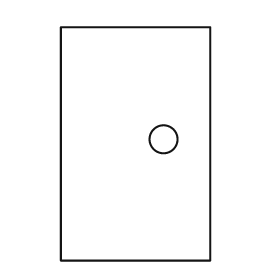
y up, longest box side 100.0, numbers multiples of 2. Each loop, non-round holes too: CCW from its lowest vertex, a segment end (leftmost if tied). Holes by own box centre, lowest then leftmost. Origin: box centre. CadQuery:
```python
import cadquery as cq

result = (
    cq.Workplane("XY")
    .moveTo(-32.0, -50.0)
    .lineTo(32.0, -50.0)
    .lineTo(32.0, 50.0)
    .lineTo(-32.0, 50.0)
    .close()
    .moveTo(12.0, 2.0)
    .circle(6.0)
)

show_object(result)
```